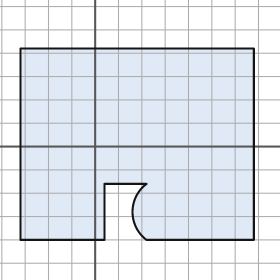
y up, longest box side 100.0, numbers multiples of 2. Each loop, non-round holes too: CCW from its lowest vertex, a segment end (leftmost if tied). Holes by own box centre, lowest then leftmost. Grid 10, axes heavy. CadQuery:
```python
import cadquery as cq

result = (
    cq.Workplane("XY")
    .moveTo(-32.0, -40.0)
    .lineTo(4.0, -40.0)
    .lineTo(4.0, -16.0)
    .lineTo(22.0, -16.0)
    .threePointArc((16.0, -28.0), (22.0, -40.0))
    .lineTo(68.0, -40.0)
    .lineTo(68.0, 42.0)
    .lineTo(-32.0, 42.0)
    .close()
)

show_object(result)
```